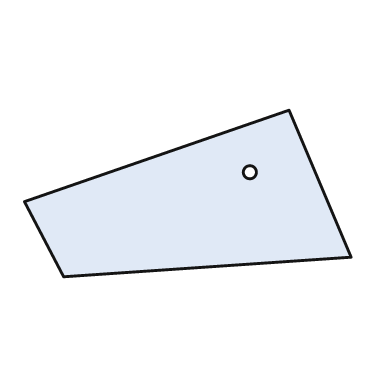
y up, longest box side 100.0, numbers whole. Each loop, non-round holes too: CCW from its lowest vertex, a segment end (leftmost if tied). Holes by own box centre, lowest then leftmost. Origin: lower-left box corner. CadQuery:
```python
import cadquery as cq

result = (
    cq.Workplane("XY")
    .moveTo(12.0, 0.0)
    .lineTo(100.0, 6.0)
    .lineTo(81.0, 51.0)
    .lineTo(0.0, 23.0)
    .close()
    .moveTo(69.0, 32.0)
    .circle(2.0)
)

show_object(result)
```